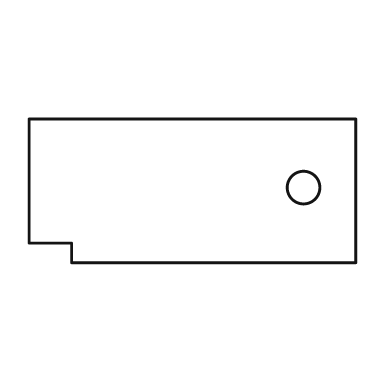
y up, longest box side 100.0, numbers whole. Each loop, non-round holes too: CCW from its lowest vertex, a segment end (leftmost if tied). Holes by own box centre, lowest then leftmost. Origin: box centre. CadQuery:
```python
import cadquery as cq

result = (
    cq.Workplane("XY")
    .moveTo(-37.0, -22.0)
    .lineTo(50.0, -22.0)
    .lineTo(50.0, 22.0)
    .lineTo(-50.0, 22.0)
    .lineTo(-50.0, -16.0)
    .lineTo(-37.0, -16.0)
    .close()
    .moveTo(34.0, 1.0)
    .circle(5.0)
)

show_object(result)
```